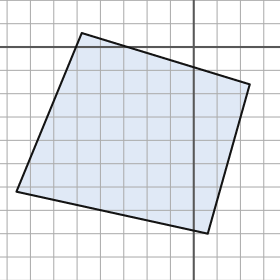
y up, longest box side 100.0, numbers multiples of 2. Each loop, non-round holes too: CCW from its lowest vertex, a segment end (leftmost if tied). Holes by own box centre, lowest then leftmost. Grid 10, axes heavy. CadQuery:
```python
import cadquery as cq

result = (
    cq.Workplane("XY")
    .moveTo(6.0, -80.0)
    .lineTo(24.0, -16.0)
    .lineTo(-48.0, 6.0)
    .lineTo(-76.0, -62.0)
    .close()
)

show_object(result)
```